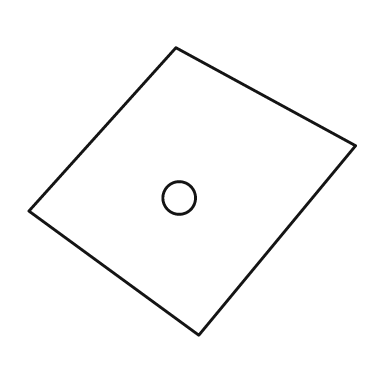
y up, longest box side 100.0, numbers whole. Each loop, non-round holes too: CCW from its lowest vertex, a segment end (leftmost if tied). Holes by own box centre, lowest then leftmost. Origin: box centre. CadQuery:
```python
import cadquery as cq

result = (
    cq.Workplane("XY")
    .moveTo(2.0, -44.0)
    .lineTo(50.0, 14.0)
    .lineTo(-5.0, 44.0)
    .lineTo(-50.0, -6.0)
    .close()
    .moveTo(-4.0, -2.0)
    .circle(5.0)
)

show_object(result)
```